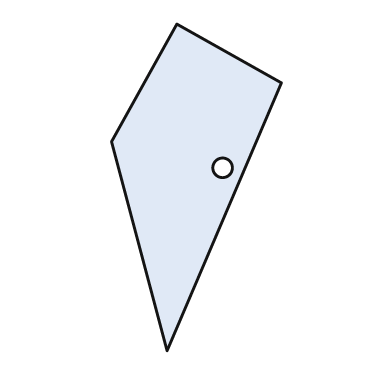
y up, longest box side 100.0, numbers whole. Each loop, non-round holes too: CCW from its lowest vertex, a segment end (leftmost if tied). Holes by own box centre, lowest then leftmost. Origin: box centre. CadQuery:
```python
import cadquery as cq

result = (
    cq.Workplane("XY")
    .moveTo(-9.0, -50.0)
    .lineTo(26.0, 32.0)
    .lineTo(-6.0, 50.0)
    .lineTo(-26.0, 14.0)
    .close()
    .moveTo(8.0, 6.0)
    .circle(3.0)
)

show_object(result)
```